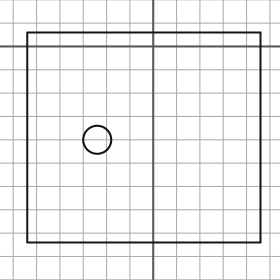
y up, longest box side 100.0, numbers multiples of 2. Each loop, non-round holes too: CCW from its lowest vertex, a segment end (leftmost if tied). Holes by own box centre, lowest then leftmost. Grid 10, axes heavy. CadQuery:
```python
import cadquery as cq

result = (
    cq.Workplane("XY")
    .moveTo(-54.0, -84.0)
    .lineTo(46.0, -84.0)
    .lineTo(46.0, 6.0)
    .lineTo(-54.0, 6.0)
    .close()
    .moveTo(-24.0, -40.0)
    .circle(6.0)
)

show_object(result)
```